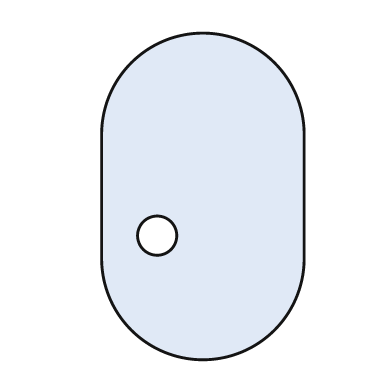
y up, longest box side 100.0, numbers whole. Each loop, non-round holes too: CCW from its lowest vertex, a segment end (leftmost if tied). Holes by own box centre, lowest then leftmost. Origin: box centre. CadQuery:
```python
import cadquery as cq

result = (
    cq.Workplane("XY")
    .moveTo(-31.0, -19.0)
    .threePointArc((0.0, -50.0), (31.0, -19.0))
    .lineTo(31.0, 19.0)
    .threePointArc((0.0, 50.0), (-31.0, 19.0))
    .close()
    .moveTo(-14.0, -12.0)
    .circle(6.0)
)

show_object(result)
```